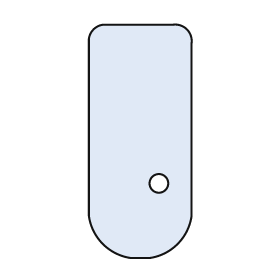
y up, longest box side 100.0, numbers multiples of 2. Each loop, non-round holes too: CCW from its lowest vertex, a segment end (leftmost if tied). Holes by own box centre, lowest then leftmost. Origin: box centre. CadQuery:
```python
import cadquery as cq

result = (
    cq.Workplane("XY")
    .moveTo(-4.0, -50.0)
    .lineTo(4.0, -50.0)
    .threePointArc((16.0, -44.0), (22.0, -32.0))
    .lineTo(22.0, 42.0)
    .threePointArc((20.0, 48.0), (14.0, 50.0))
    .lineTo(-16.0, 50.0)
    .threePointArc((-20.0, 48.0), (-22.0, 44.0))
    .lineTo(-22.0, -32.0)
    .threePointArc((-16.0, -44.0), (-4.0, -50.0))
    .close()
    .moveTo(8.0, -18.0)
    .circle(4.0)
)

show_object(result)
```